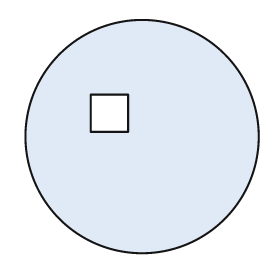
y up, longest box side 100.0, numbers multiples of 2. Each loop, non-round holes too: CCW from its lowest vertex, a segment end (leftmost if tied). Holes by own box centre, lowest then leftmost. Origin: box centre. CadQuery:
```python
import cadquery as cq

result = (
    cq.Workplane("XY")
    .moveTo(0.0, 0.0)
    .circle(50.0)
    .moveTo(-22.0, 2.0)
    .lineTo(-6.0, 2.0)
    .lineTo(-6.0, 18.0)
    .lineTo(-22.0, 18.0)
    .close()
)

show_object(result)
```